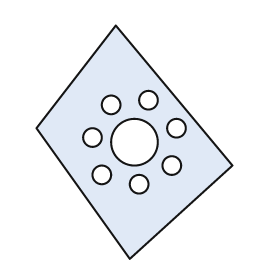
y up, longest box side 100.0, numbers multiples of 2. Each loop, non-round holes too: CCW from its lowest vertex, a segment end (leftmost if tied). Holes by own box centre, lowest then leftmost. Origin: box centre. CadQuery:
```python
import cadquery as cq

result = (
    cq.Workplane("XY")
    .moveTo(-2.0, -50.0)
    .lineTo(42.0, -10.0)
    .lineTo(-8.0, 50.0)
    .lineTo(-42.0, 6.0)
    .close()
    .moveTo(2.0, -18.0)
    .circle(4.0)
    .moveTo(-14.0, -14.0)
    .circle(4.0)
    .moveTo(16.0, -10.0)
    .circle(4.0)
    .moveTo(0.0, 0.0)
    .circle(10.0)
    .moveTo(-18.0, 2.0)
    .circle(4.0)
    .moveTo(18.0, 6.0)
    .circle(4.0)
    .moveTo(-10.0, 16.0)
    .circle(4.0)
    .moveTo(6.0, 18.0)
    .circle(4.0)
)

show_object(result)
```